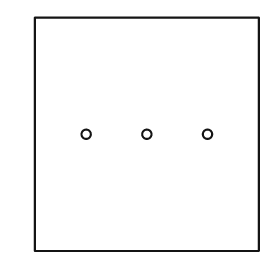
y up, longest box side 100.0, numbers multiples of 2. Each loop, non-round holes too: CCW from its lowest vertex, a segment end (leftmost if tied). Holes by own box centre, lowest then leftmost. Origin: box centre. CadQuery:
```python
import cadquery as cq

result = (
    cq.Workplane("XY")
    .moveTo(-48.0, -50.0)
    .lineTo(48.0, -50.0)
    .lineTo(48.0, 50.0)
    .lineTo(-48.0, 50.0)
    .close()
    .moveTo(-26.0, 0.0)
    .circle(2.0)
    .moveTo(0.0, 0.0)
    .circle(2.0)
    .moveTo(26.0, 0.0)
    .circle(2.0)
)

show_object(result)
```